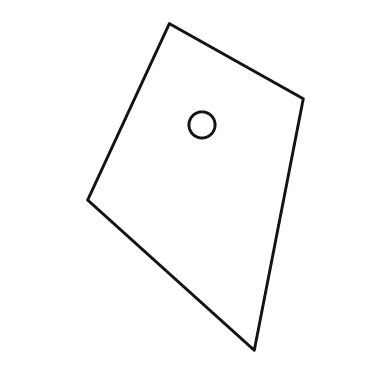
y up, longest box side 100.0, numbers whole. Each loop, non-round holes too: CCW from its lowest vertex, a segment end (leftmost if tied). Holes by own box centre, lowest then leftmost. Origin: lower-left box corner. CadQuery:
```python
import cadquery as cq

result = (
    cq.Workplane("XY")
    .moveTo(51.0, 0.0)
    .lineTo(66.0, 77.0)
    .lineTo(25.0, 100.0)
    .lineTo(0.0, 46.0)
    .close()
    .moveTo(35.0, 69.0)
    .circle(4.0)
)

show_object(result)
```